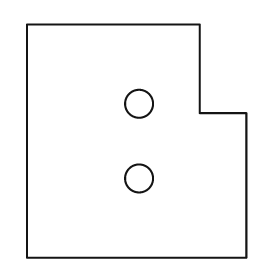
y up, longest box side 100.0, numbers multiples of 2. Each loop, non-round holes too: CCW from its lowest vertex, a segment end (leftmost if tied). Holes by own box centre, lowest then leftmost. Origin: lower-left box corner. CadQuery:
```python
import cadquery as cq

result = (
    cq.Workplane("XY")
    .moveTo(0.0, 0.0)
    .lineTo(94.0, 0.0)
    .lineTo(94.0, 62.0)
    .lineTo(74.0, 62.0)
    .lineTo(74.0, 100.0)
    .lineTo(0.0, 100.0)
    .close()
    .moveTo(48.0, 34.0)
    .circle(6.0)
    .moveTo(48.0, 66.0)
    .circle(6.0)
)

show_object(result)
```